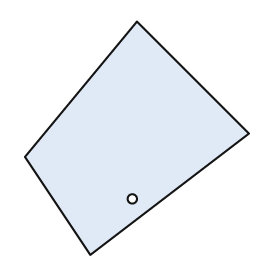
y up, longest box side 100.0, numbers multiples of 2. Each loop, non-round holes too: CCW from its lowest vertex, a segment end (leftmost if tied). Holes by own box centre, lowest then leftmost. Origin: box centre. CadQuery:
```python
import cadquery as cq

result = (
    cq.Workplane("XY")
    .moveTo(-20.0, -50.0)
    .lineTo(48.0, 2.0)
    .lineTo(0.0, 50.0)
    .lineTo(-48.0, -8.0)
    .close()
    .moveTo(-2.0, -26.0)
    .circle(2.0)
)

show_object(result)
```